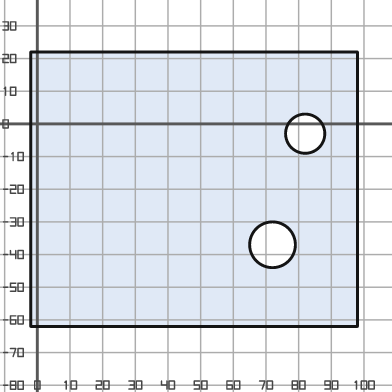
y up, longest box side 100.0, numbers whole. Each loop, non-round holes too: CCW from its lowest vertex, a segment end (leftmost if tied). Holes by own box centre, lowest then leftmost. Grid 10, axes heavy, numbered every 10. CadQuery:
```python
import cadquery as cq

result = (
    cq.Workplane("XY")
    .moveTo(-2.0, -62.0)
    .lineTo(98.0, -62.0)
    .lineTo(98.0, 22.0)
    .lineTo(-2.0, 22.0)
    .close()
    .moveTo(72.0, -37.0)
    .circle(7.0)
    .moveTo(82.0, -3.0)
    .circle(6.0)
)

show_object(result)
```